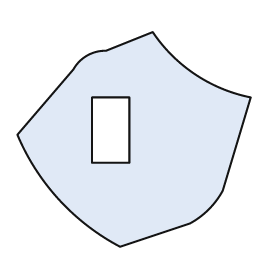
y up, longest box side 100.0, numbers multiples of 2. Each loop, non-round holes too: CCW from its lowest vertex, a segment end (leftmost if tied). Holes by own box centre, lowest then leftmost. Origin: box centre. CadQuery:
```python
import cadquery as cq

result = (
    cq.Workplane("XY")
    .moveTo(-6.0, -46.0)
    .lineTo(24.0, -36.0)
    .threePointArc((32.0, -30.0), (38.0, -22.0))
    .lineTo(50.0, 18.0)
    .threePointArc((26.0, 28.0), (8.0, 46.0))
    .lineTo(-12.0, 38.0)
    .threePointArc((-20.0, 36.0), (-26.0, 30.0))
    .lineTo(-50.0, 2.0)
    .threePointArc((-32.0, -26.0), (-6.0, -46.0))
    .close()
    .moveTo(-18.0, -10.0)
    .lineTo(-2.0, -10.0)
    .lineTo(-2.0, 18.0)
    .lineTo(-18.0, 18.0)
    .close()
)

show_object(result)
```